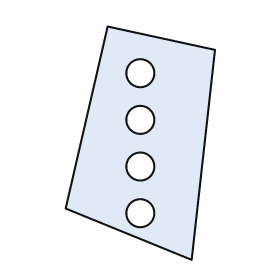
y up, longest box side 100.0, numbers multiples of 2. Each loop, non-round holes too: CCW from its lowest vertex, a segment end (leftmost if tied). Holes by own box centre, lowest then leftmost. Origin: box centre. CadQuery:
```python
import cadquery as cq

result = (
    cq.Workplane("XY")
    .moveTo(22.0, -50.0)
    .lineTo(32.0, 40.0)
    .lineTo(-14.0, 50.0)
    .lineTo(-32.0, -28.0)
    .close()
    .moveTo(0.0, -30.0)
    .circle(6.0)
    .moveTo(0.0, -10.0)
    .circle(6.0)
    .moveTo(0.0, 10.0)
    .circle(6.0)
    .moveTo(0.0, 30.0)
    .circle(6.0)
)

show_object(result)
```